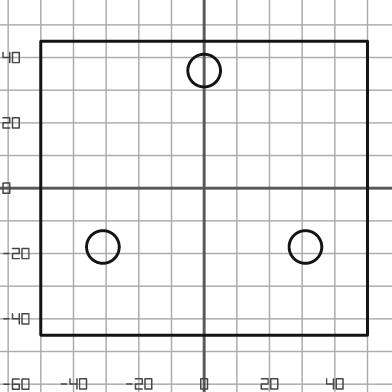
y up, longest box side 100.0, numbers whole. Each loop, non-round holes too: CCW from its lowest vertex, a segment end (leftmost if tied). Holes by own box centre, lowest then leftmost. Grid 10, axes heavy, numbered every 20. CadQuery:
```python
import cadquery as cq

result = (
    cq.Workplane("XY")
    .moveTo(-50.0, -45.0)
    .lineTo(50.0, -45.0)
    .lineTo(50.0, 45.0)
    .lineTo(-50.0, 45.0)
    .close()
    .moveTo(-31.0, -18.0)
    .circle(5.0)
    .moveTo(31.0, -18.0)
    .circle(5.0)
    .moveTo(0.0, 36.0)
    .circle(5.0)
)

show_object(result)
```